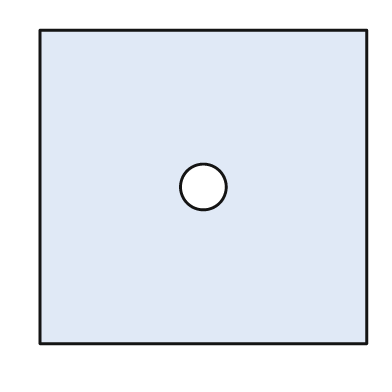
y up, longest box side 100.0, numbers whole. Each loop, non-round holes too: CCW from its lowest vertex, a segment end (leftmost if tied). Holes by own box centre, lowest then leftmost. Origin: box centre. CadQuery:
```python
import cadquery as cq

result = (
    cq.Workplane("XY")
    .moveTo(-50.0, -48.0)
    .lineTo(50.0, -48.0)
    .lineTo(50.0, 48.0)
    .lineTo(-50.0, 48.0)
    .close()
    .moveTo(0.0, 0.0)
    .circle(7.0)
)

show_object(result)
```